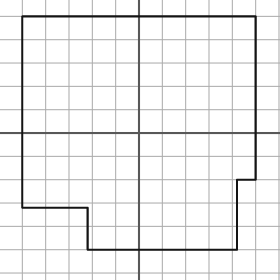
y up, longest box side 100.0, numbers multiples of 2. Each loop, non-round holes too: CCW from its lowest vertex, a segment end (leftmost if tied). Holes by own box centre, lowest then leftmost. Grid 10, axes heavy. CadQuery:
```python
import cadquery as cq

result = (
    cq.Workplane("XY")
    .moveTo(-22.0, -50.0)
    .lineTo(42.0, -50.0)
    .lineTo(42.0, -20.0)
    .lineTo(50.0, -20.0)
    .lineTo(50.0, 50.0)
    .lineTo(-50.0, 50.0)
    .lineTo(-50.0, -32.0)
    .lineTo(-22.0, -32.0)
    .close()
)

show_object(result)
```